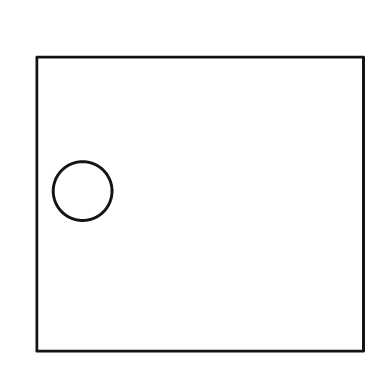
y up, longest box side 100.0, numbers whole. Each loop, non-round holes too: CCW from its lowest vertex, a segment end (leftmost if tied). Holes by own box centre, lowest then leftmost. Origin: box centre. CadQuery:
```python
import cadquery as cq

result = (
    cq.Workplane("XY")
    .moveTo(-50.0, -45.0)
    .lineTo(50.0, -45.0)
    .lineTo(50.0, 45.0)
    .lineTo(-50.0, 45.0)
    .close()
    .moveTo(-36.0, 4.0)
    .circle(9.0)
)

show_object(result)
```